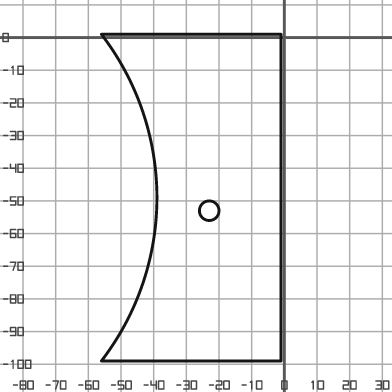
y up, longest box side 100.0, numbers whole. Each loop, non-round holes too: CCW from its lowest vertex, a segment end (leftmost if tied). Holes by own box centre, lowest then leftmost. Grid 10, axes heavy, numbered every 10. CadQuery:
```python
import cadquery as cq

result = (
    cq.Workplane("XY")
    .moveTo(-56.0, -99.0)
    .lineTo(-1.0, -99.0)
    .lineTo(-1.0, 1.0)
    .lineTo(-56.0, 1.0)
    .threePointArc((-39.0, -49.0), (-56.0, -99.0))
    .close()
    .moveTo(-23.0, -53.0)
    .circle(3.0)
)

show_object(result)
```